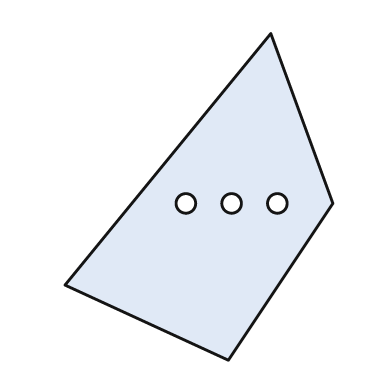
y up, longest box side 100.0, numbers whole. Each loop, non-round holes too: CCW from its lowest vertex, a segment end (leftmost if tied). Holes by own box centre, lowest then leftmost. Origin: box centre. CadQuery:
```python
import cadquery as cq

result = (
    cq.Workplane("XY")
    .moveTo(9.0, -50.0)
    .lineTo(41.0, -2.0)
    .lineTo(22.0, 50.0)
    .lineTo(-41.0, -27.0)
    .close()
    .moveTo(-4.0, -2.0)
    .circle(3.0)
    .moveTo(10.0, -2.0)
    .circle(3.0)
    .moveTo(24.0, -2.0)
    .circle(3.0)
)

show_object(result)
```